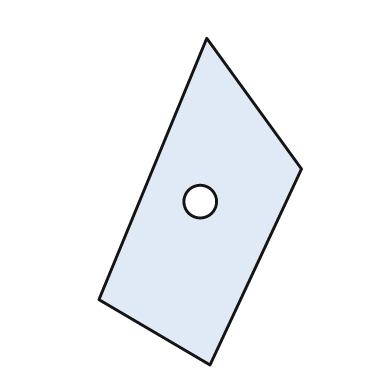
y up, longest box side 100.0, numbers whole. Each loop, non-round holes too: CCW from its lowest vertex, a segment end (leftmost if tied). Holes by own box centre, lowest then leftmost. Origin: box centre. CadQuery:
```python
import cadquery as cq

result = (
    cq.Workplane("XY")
    .moveTo(3.0, -50.0)
    .lineTo(31.0, 10.0)
    .lineTo(2.0, 50.0)
    .lineTo(-31.0, -30.0)
    .close()
    .moveTo(0.0, 0.0)
    .circle(5.0)
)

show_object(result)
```